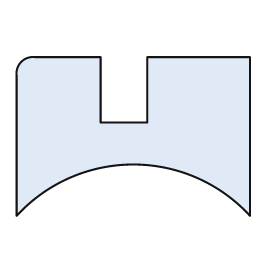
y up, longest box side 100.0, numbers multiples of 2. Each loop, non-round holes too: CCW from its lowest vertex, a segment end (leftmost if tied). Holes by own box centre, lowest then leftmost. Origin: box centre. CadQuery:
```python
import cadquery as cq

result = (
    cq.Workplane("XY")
    .moveTo(-50.0, -34.0)
    .threePointArc((0.0, -12.0), (50.0, -34.0))
    .lineTo(50.0, 34.0)
    .lineTo(6.0, 34.0)
    .lineTo(6.0, 6.0)
    .lineTo(-14.0, 6.0)
    .lineTo(-14.0, 34.0)
    .lineTo(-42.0, 34.0)
    .threePointArc((-48.0, 32.0), (-50.0, 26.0))
    .close()
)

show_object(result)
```